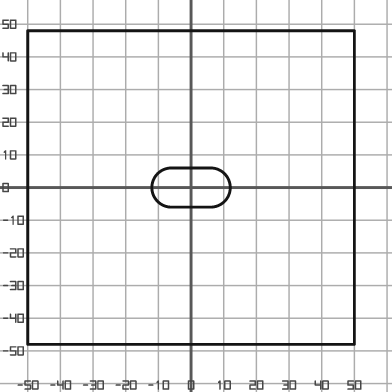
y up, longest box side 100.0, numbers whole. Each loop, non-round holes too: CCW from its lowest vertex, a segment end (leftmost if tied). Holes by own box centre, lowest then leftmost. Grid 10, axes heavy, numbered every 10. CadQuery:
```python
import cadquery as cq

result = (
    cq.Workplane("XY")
    .moveTo(-50.0, -48.0)
    .lineTo(50.0, -48.0)
    .lineTo(50.0, 48.0)
    .lineTo(-50.0, 48.0)
    .close()
    .moveTo(-6.0, -6.0)
    .lineTo(6.0, -6.0)
    .threePointArc((12.0, 0.0), (6.0, 6.0))
    .lineTo(-6.0, 6.0)
    .threePointArc((-12.0, 0.0), (-6.0, -6.0))
    .close()
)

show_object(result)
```